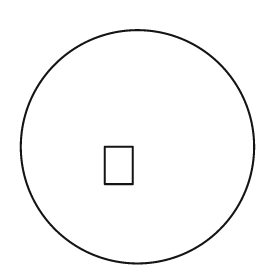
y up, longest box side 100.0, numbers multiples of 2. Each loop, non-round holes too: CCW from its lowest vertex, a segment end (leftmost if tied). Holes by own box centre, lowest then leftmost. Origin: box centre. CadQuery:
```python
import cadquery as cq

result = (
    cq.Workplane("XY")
    .moveTo(0.0, 0.0)
    .circle(50.0)
    .moveTo(-14.0, -16.0)
    .lineTo(-2.0, -16.0)
    .lineTo(-2.0, 0.0)
    .lineTo(-14.0, 0.0)
    .close()
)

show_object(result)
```